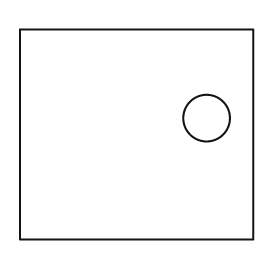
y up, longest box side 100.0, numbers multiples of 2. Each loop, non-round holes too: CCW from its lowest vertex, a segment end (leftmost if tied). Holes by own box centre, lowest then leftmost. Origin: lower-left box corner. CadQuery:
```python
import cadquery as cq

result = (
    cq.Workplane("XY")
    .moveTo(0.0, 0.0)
    .lineTo(100.0, 0.0)
    .lineTo(100.0, 90.0)
    .lineTo(0.0, 90.0)
    .close()
    .moveTo(80.0, 52.0)
    .circle(10.0)
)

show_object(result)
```